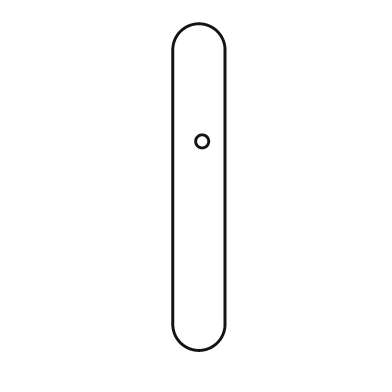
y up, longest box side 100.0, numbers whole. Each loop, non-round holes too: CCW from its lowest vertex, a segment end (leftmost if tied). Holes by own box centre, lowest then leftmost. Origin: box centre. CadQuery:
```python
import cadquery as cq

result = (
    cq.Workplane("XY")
    .moveTo(-8.0, -42.0)
    .threePointArc((0.0, -50.0), (8.0, -42.0))
    .lineTo(8.0, 42.0)
    .threePointArc((0.0, 50.0), (-8.0, 42.0))
    .close()
    .moveTo(1.0, 14.0)
    .circle(2.0)
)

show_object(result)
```